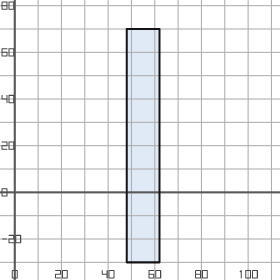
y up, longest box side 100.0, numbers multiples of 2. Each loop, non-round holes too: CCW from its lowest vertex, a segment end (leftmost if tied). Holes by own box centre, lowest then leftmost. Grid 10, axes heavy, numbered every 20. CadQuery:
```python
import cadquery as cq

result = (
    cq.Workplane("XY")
    .moveTo(48.0, -30.0)
    .lineTo(62.0, -30.0)
    .lineTo(62.0, 70.0)
    .lineTo(48.0, 70.0)
    .close()
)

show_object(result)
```